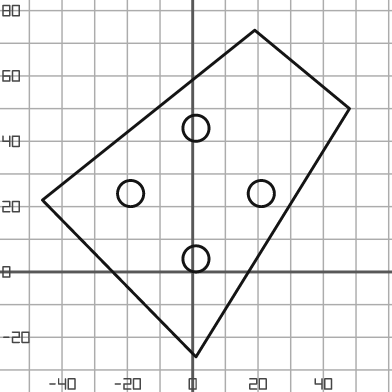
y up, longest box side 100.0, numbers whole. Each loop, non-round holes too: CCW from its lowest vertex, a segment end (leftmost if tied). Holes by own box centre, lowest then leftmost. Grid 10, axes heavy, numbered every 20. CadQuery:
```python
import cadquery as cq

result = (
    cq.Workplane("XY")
    .moveTo(1.0, -26.0)
    .lineTo(48.0, 50.0)
    .lineTo(19.0, 74.0)
    .lineTo(-46.0, 22.0)
    .close()
    .moveTo(1.0, 4.0)
    .circle(4.0)
    .moveTo(-19.0, 24.0)
    .circle(4.0)
    .moveTo(21.0, 24.0)
    .circle(4.0)
    .moveTo(1.0, 44.0)
    .circle(4.0)
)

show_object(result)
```